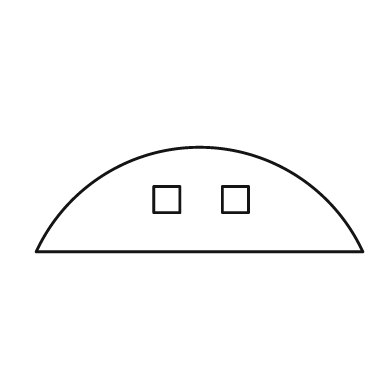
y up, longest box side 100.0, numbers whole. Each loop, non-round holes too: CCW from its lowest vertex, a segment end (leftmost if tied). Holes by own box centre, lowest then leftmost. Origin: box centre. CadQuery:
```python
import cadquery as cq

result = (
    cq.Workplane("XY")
    .moveTo(-50.0, -16.0)
    .lineTo(50.0, -16.0)
    .threePointArc((0.0, 16.0), (-50.0, -16.0))
    .close()
    .moveTo(-14.0, -4.0)
    .lineTo(-6.0, -4.0)
    .lineTo(-6.0, 4.0)
    .lineTo(-14.0, 4.0)
    .close()
    .moveTo(7.0, -4.0)
    .lineTo(15.0, -4.0)
    .lineTo(15.0, 4.0)
    .lineTo(7.0, 4.0)
    .close()
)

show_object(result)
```